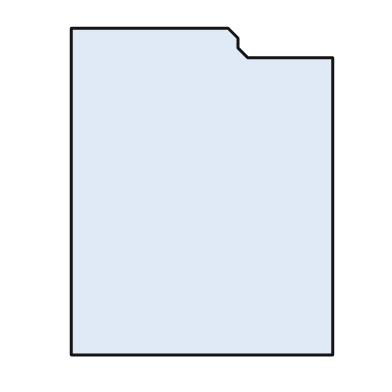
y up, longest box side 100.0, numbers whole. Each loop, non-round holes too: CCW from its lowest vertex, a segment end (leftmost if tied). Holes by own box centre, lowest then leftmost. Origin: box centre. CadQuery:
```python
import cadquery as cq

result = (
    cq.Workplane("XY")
    .moveTo(-40.0, -50.0)
    .lineTo(40.0, -50.0)
    .lineTo(40.0, 41.0)
    .lineTo(14.0, 41.0)
    .lineTo(11.0, 44.0)
    .lineTo(11.0, 47.0)
    .lineTo(8.0, 50.0)
    .lineTo(-40.0, 50.0)
    .close()
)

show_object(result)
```